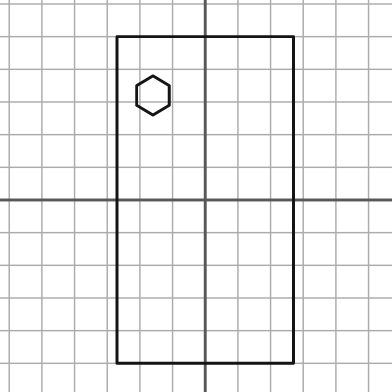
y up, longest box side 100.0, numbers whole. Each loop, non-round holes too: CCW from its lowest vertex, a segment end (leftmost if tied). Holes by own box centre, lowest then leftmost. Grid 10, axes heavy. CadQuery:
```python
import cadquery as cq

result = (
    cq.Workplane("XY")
    .moveTo(-27.0, -50.0)
    .lineTo(27.0, -50.0)
    .lineTo(27.0, 50.0)
    .lineTo(-27.0, 50.0)
    .close()
    .moveTo(-16.0, 26.0)
    .lineTo(-11.0, 29.0)
    .lineTo(-11.0, 35.0)
    .lineTo(-16.0, 38.0)
    .lineTo(-21.0, 35.0)
    .lineTo(-21.0, 29.0)
    .close()
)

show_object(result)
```